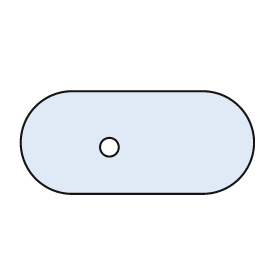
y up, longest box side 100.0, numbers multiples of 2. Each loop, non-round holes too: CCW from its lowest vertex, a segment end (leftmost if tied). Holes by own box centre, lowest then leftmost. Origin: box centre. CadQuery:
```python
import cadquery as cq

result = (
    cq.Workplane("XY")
    .moveTo(-28.0, -22.0)
    .lineTo(28.0, -22.0)
    .threePointArc((50.0, 0.0), (28.0, 22.0))
    .lineTo(-28.0, 22.0)
    .threePointArc((-50.0, 0.0), (-28.0, -22.0))
    .close()
    .moveTo(-12.0, -2.0)
    .circle(4.0)
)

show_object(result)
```